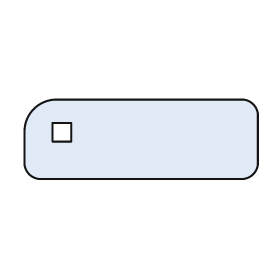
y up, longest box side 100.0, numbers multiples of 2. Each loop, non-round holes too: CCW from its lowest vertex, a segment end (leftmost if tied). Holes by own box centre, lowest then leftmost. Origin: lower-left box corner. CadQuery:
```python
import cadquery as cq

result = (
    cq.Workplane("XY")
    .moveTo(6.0, 0.0)
    .lineTo(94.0, 0.0)
    .threePointArc((98.0, 2.0), (100.0, 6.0))
    .lineTo(100.0, 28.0)
    .threePointArc((98.0, 32.0), (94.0, 34.0))
    .lineTo(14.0, 34.0)
    .threePointArc((4.0, 30.0), (0.0, 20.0))
    .lineTo(0.0, 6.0)
    .threePointArc((2.0, 2.0), (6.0, 0.0))
    .close()
    .moveTo(12.0, 16.0)
    .lineTo(20.0, 16.0)
    .lineTo(20.0, 24.0)
    .lineTo(12.0, 24.0)
    .close()
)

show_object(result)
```